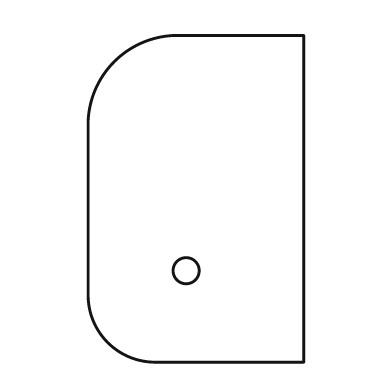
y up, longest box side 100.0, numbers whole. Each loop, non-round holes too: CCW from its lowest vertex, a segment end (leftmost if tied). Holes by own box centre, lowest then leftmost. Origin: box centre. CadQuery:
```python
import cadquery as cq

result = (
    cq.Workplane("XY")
    .moveTo(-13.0, -50.0)
    .lineTo(33.0, -50.0)
    .lineTo(33.0, 50.0)
    .lineTo(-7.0, 50.0)
    .threePointArc((-25.0, 42.0), (-33.0, 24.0))
    .lineTo(-33.0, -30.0)
    .threePointArc((-27.0, -44.0), (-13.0, -50.0))
    .close()
    .moveTo(-3.0, -22.0)
    .circle(4.0)
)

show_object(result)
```